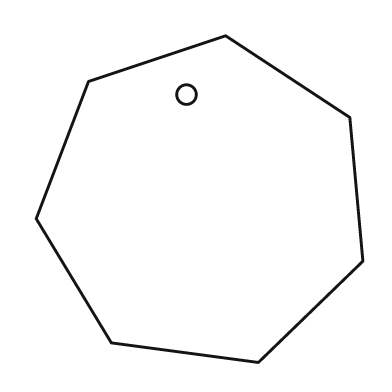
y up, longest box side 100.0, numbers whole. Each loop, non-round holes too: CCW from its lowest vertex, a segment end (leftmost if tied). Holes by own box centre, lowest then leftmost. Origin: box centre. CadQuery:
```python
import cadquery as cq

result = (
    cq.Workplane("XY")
    .moveTo(18.0, -50.0)
    .lineTo(50.0, -19.0)
    .lineTo(46.0, 25.0)
    .lineTo(8.0, 50.0)
    .lineTo(-34.0, 36.0)
    .lineTo(-50.0, -6.0)
    .lineTo(-27.0, -44.0)
    .close()
    .moveTo(-4.0, 32.0)
    .circle(3.0)
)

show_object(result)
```